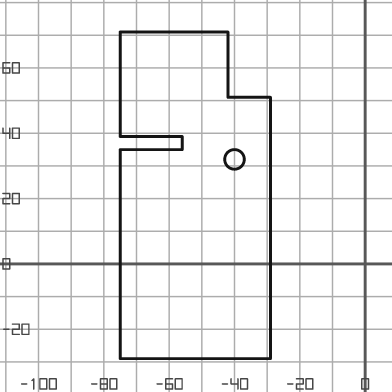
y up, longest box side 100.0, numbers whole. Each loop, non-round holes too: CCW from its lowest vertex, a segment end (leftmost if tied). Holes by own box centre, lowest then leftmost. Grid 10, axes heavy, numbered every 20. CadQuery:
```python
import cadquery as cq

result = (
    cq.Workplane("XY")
    .moveTo(-75.0, -29.0)
    .lineTo(-29.0, -29.0)
    .lineTo(-29.0, 51.0)
    .lineTo(-42.0, 51.0)
    .lineTo(-42.0, 71.0)
    .lineTo(-75.0, 71.0)
    .lineTo(-75.0, 39.0)
    .lineTo(-56.0, 39.0)
    .lineTo(-56.0, 35.0)
    .lineTo(-75.0, 35.0)
    .close()
    .moveTo(-40.0, 32.0)
    .circle(3.0)
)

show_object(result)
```